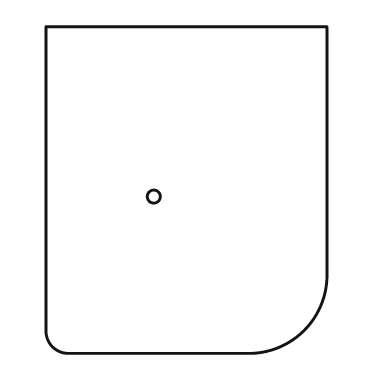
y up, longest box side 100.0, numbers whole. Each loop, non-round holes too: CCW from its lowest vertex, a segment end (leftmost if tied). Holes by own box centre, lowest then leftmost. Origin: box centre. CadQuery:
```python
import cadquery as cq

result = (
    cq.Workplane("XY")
    .moveTo(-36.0, -50.0)
    .lineTo(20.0, -50.0)
    .threePointArc((36.0, -43.0), (43.0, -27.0))
    .lineTo(43.0, 50.0)
    .lineTo(-43.0, 50.0)
    .lineTo(-43.0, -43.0)
    .threePointArc((-41.0, -48.0), (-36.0, -50.0))
    .close()
    .moveTo(-10.0, -2.0)
    .circle(2.0)
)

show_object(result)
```